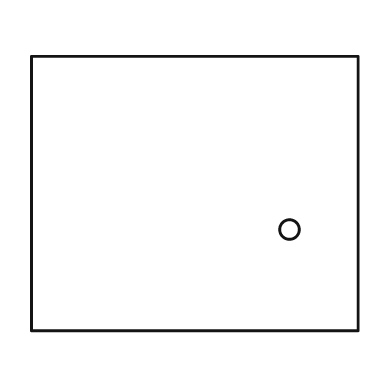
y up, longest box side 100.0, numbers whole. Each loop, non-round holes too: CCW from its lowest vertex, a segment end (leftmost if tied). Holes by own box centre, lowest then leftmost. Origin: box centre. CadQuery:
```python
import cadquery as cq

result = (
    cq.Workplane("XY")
    .moveTo(-50.0, -42.0)
    .lineTo(50.0, -42.0)
    .lineTo(50.0, 42.0)
    .lineTo(-50.0, 42.0)
    .close()
    .moveTo(29.0, -11.0)
    .circle(3.0)
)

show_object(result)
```